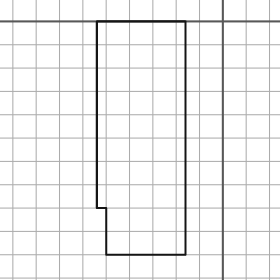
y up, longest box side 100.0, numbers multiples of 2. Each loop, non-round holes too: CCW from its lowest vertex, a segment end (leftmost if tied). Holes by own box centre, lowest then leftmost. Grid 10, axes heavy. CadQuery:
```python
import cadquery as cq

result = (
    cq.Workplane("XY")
    .moveTo(-50.0, -100.0)
    .lineTo(-16.0, -100.0)
    .lineTo(-16.0, 0.0)
    .lineTo(-54.0, 0.0)
    .lineTo(-54.0, -80.0)
    .lineTo(-50.0, -80.0)
    .close()
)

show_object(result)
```